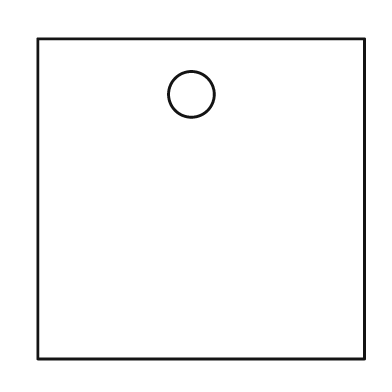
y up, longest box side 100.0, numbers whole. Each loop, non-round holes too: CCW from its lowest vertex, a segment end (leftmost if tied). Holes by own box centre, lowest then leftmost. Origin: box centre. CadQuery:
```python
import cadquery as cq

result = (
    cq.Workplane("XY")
    .moveTo(-50.0, -49.0)
    .lineTo(50.0, -49.0)
    .lineTo(50.0, 49.0)
    .lineTo(-50.0, 49.0)
    .close()
    .moveTo(-3.0, 32.0)
    .circle(7.0)
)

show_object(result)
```